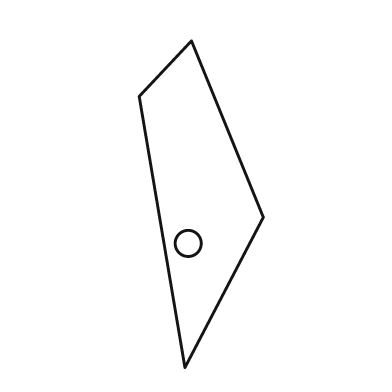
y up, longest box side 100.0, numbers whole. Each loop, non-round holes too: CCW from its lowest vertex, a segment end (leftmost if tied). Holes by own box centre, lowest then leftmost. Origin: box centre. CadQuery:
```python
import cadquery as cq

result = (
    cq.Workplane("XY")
    .moveTo(-5.0, -50.0)
    .lineTo(19.0, -4.0)
    .lineTo(-3.0, 50.0)
    .lineTo(-19.0, 33.0)
    .close()
    .moveTo(-4.0, -12.0)
    .circle(4.0)
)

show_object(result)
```